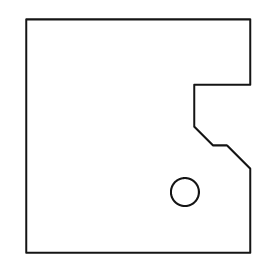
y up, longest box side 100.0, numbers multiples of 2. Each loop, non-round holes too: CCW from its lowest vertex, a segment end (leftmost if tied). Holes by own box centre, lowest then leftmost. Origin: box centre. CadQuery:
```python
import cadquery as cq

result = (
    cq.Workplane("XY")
    .moveTo(-48.0, -50.0)
    .lineTo(48.0, -50.0)
    .lineTo(48.0, -14.0)
    .lineTo(38.0, -4.0)
    .lineTo(32.0, -4.0)
    .lineTo(24.0, 4.0)
    .lineTo(24.0, 22.0)
    .lineTo(48.0, 22.0)
    .lineTo(48.0, 50.0)
    .lineTo(-48.0, 50.0)
    .close()
    .moveTo(20.0, -24.0)
    .circle(6.0)
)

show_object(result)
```